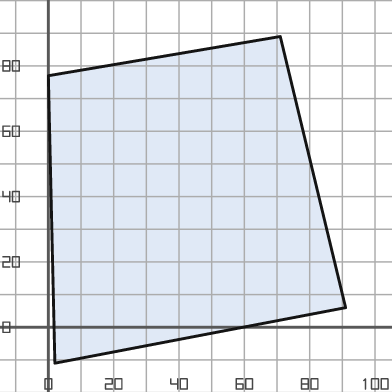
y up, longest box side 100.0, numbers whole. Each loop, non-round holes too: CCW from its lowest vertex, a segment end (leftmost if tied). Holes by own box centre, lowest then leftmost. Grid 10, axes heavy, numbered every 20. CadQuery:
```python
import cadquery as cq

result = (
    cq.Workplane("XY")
    .moveTo(2.0, -11.0)
    .lineTo(91.0, 6.0)
    .lineTo(71.0, 89.0)
    .lineTo(0.0, 77.0)
    .close()
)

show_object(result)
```